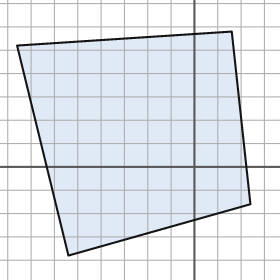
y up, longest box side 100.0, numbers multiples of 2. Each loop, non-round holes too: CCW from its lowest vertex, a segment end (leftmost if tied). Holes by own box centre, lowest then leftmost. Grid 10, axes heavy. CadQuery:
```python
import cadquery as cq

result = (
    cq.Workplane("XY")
    .moveTo(-54.0, -38.0)
    .lineTo(24.0, -16.0)
    .lineTo(16.0, 58.0)
    .lineTo(-76.0, 52.0)
    .close()
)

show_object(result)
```